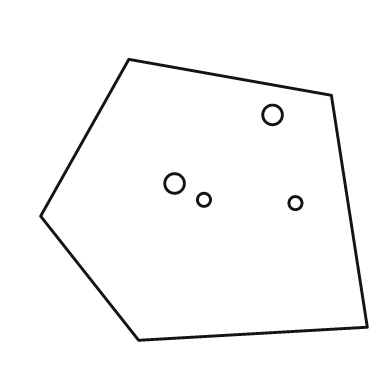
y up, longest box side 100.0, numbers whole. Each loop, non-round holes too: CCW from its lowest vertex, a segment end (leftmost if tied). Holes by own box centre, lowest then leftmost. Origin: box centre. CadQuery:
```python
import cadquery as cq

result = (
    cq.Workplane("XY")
    .moveTo(-20.0, -43.0)
    .lineTo(50.0, -39.0)
    .lineTo(39.0, 32.0)
    .lineTo(-23.0, 43.0)
    .lineTo(-50.0, -5.0)
    .close()
    .moveTo(28.0, -1.0)
    .circle(2.0)
    .moveTo(0.0, 0.0)
    .circle(2.0)
    .moveTo(-9.0, 5.0)
    .circle(3.0)
    .moveTo(21.0, 26.0)
    .circle(3.0)
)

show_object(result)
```